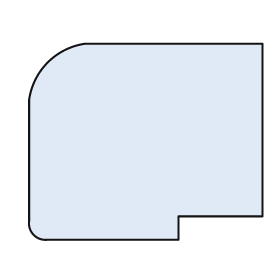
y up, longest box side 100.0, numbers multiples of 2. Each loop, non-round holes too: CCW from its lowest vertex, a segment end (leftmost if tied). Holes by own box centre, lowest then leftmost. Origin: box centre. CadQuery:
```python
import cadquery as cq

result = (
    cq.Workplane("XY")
    .moveTo(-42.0, -42.0)
    .lineTo(14.0, -42.0)
    .lineTo(14.0, -32.0)
    .lineTo(50.0, -32.0)
    .lineTo(50.0, 42.0)
    .lineTo(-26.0, 42.0)
    .threePointArc((-42.0, 34.0), (-50.0, 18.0))
    .lineTo(-50.0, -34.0)
    .threePointArc((-48.0, -40.0), (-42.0, -42.0))
    .close()
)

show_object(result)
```